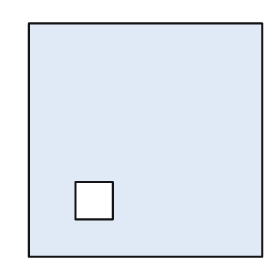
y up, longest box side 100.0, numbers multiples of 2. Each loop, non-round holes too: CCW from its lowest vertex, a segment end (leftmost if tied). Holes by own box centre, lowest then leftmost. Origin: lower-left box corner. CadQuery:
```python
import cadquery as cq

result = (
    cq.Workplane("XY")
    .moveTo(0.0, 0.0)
    .lineTo(100.0, 0.0)
    .lineTo(100.0, 100.0)
    .lineTo(0.0, 100.0)
    .close()
    .moveTo(20.0, 16.0)
    .lineTo(36.0, 16.0)
    .lineTo(36.0, 32.0)
    .lineTo(20.0, 32.0)
    .close()
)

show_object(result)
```